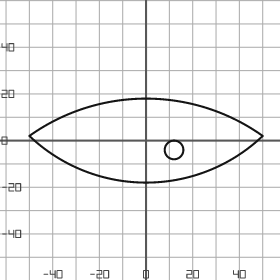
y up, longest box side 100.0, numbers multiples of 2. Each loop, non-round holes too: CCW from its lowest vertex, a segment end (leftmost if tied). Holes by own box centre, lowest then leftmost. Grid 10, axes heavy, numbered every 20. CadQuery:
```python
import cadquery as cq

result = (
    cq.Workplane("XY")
    .moveTo(-50.0, 2.0)
    .threePointArc((0.0, -18.0), (50.0, 2.0))
    .threePointArc((0.0, 18.0), (-50.0, 2.0))
    .close()
    .moveTo(12.0, -4.0)
    .circle(4.0)
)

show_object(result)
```